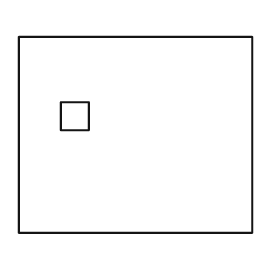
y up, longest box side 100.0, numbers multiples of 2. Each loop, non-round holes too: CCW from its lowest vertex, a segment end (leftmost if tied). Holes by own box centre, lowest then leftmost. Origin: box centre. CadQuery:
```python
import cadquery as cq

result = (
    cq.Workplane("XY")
    .moveTo(-50.0, -42.0)
    .lineTo(50.0, -42.0)
    .lineTo(50.0, 42.0)
    .lineTo(-50.0, 42.0)
    .close()
    .moveTo(-32.0, 2.0)
    .lineTo(-20.0, 2.0)
    .lineTo(-20.0, 14.0)
    .lineTo(-32.0, 14.0)
    .close()
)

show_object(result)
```